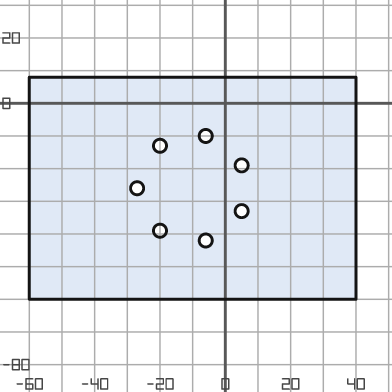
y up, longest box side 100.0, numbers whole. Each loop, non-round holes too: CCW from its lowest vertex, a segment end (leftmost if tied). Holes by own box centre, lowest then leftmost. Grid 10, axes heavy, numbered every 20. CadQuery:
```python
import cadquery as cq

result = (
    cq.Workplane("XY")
    .moveTo(-60.0, -60.0)
    .lineTo(40.0, -60.0)
    .lineTo(40.0, 8.0)
    .lineTo(-60.0, 8.0)
    .close()
    .moveTo(-6.0, -42.0)
    .circle(2.0)
    .moveTo(-20.0, -39.0)
    .circle(2.0)
    .moveTo(5.0, -33.0)
    .circle(2.0)
    .moveTo(-27.0, -26.0)
    .circle(2.0)
    .moveTo(5.0, -19.0)
    .circle(2.0)
    .moveTo(-20.0, -13.0)
    .circle(2.0)
    .moveTo(-6.0, -10.0)
    .circle(2.0)
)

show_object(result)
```